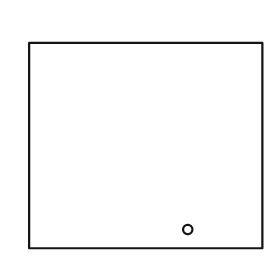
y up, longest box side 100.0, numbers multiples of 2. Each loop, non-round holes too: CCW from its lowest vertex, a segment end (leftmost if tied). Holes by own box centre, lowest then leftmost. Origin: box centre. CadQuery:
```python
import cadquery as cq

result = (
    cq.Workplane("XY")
    .moveTo(-50.0, -44.0)
    .lineTo(50.0, -44.0)
    .lineTo(50.0, 44.0)
    .lineTo(-50.0, 44.0)
    .close()
    .moveTo(18.0, -36.0)
    .circle(2.0)
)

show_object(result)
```